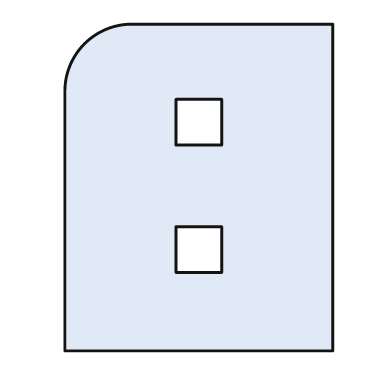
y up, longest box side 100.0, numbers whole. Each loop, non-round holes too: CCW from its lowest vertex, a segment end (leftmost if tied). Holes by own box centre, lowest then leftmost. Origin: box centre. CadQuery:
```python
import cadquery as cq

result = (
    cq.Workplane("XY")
    .moveTo(-41.0, -50.0)
    .lineTo(41.0, -50.0)
    .lineTo(41.0, 50.0)
    .lineTo(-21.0, 50.0)
    .threePointArc((-35.0, 44.0), (-41.0, 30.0))
    .close()
    .moveTo(-7.0, -26.0)
    .lineTo(7.0, -26.0)
    .lineTo(7.0, -12.0)
    .lineTo(-7.0, -12.0)
    .close()
    .moveTo(-7.0, 13.0)
    .lineTo(7.0, 13.0)
    .lineTo(7.0, 27.0)
    .lineTo(-7.0, 27.0)
    .close()
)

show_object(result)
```